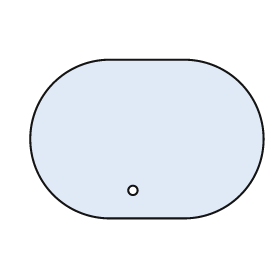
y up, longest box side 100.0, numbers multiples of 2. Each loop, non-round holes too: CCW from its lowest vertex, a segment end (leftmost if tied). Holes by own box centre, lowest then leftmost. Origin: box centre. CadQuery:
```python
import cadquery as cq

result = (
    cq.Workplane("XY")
    .moveTo(-16.0, -34.0)
    .lineTo(16.0, -34.0)
    .threePointArc((50.0, 0.0), (16.0, 34.0))
    .lineTo(-16.0, 34.0)
    .threePointArc((-50.0, 0.0), (-16.0, -34.0))
    .close()
    .moveTo(-6.0, -22.0)
    .circle(2.0)
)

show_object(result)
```